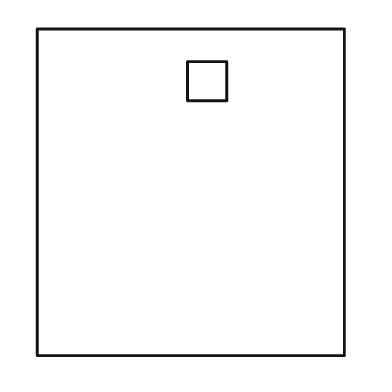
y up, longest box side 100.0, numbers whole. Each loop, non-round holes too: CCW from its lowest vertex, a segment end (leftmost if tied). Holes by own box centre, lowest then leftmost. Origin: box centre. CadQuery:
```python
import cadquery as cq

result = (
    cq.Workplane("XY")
    .moveTo(-47.0, -50.0)
    .lineTo(47.0, -50.0)
    .lineTo(47.0, 50.0)
    .lineTo(-47.0, 50.0)
    .close()
    .moveTo(-1.0, 28.0)
    .lineTo(11.0, 28.0)
    .lineTo(11.0, 40.0)
    .lineTo(-1.0, 40.0)
    .close()
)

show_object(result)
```